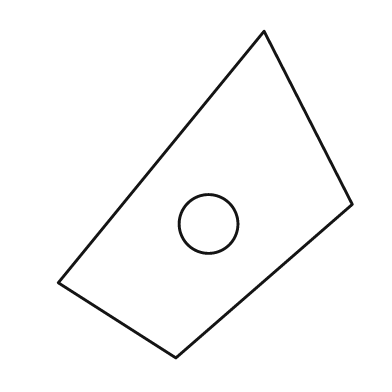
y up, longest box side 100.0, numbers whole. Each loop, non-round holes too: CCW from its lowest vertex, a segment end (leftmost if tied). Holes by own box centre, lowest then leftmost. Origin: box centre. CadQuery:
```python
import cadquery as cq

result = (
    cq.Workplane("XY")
    .moveTo(-9.0, -50.0)
    .lineTo(45.0, -3.0)
    .lineTo(18.0, 50.0)
    .lineTo(-45.0, -27.0)
    .close()
    .moveTo(1.0, -9.0)
    .circle(9.0)
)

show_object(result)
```